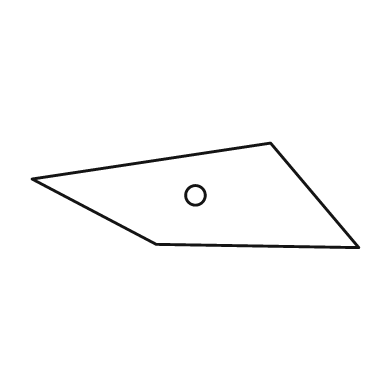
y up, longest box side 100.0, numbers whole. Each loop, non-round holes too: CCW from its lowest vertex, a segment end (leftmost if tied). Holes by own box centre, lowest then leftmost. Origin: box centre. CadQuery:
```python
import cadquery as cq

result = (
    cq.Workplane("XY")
    .moveTo(50.0, -16.0)
    .lineTo(23.0, 16.0)
    .lineTo(-50.0, 5.0)
    .lineTo(-12.0, -15.0)
    .close()
    .moveTo(0.0, 0.0)
    .circle(3.0)
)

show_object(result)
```